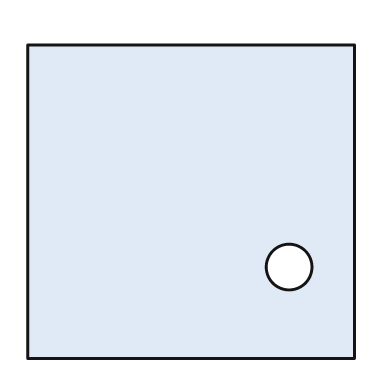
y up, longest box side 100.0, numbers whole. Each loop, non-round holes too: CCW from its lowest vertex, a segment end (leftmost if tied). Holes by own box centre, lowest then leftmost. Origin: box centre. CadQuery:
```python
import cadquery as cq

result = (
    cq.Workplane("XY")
    .moveTo(-50.0, -48.0)
    .lineTo(50.0, -48.0)
    .lineTo(50.0, 48.0)
    .lineTo(-50.0, 48.0)
    .close()
    .moveTo(30.0, -20.0)
    .circle(7.0)
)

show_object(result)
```